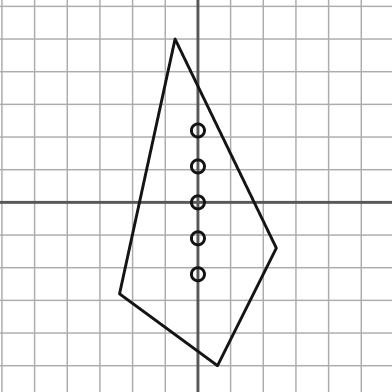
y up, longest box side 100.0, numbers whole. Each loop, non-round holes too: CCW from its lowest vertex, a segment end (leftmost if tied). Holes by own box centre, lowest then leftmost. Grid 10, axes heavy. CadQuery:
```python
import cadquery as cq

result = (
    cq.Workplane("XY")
    .moveTo(6.0, -50.0)
    .lineTo(24.0, -14.0)
    .lineTo(-7.0, 50.0)
    .lineTo(-24.0, -28.0)
    .close()
    .moveTo(0.0, -22.0)
    .circle(2.0)
    .moveTo(0.0, -11.0)
    .circle(2.0)
    .moveTo(0.0, 0.0)
    .circle(2.0)
    .moveTo(0.0, 11.0)
    .circle(2.0)
    .moveTo(0.0, 22.0)
    .circle(2.0)
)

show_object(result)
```